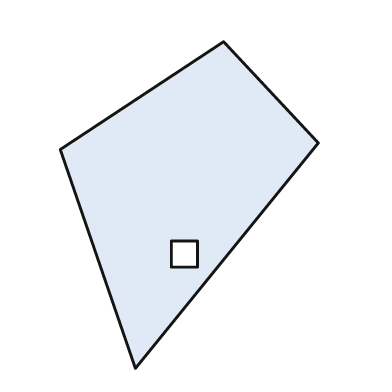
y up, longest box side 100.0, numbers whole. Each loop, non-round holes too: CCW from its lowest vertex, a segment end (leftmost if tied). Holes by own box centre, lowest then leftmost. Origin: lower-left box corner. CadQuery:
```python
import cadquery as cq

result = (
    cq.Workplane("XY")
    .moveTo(23.0, 0.0)
    .lineTo(79.0, 69.0)
    .lineTo(50.0, 100.0)
    .lineTo(0.0, 67.0)
    .close()
    .moveTo(34.0, 31.0)
    .lineTo(42.0, 31.0)
    .lineTo(42.0, 39.0)
    .lineTo(34.0, 39.0)
    .close()
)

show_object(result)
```